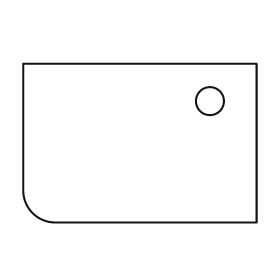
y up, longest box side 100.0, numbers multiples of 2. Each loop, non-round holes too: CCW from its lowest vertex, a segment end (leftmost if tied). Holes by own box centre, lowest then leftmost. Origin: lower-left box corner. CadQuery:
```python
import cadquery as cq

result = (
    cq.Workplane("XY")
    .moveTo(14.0, 0.0)
    .lineTo(100.0, 0.0)
    .lineTo(100.0, 68.0)
    .lineTo(0.0, 68.0)
    .lineTo(0.0, 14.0)
    .threePointArc((4.0, 4.0), (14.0, 0.0))
    .close()
    .moveTo(80.0, 52.0)
    .circle(6.0)
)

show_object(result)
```